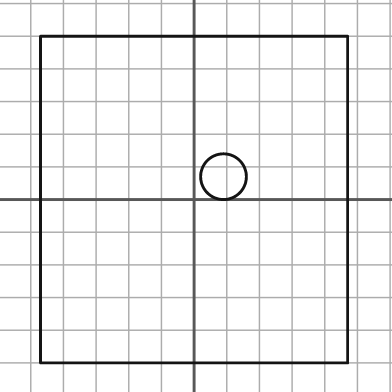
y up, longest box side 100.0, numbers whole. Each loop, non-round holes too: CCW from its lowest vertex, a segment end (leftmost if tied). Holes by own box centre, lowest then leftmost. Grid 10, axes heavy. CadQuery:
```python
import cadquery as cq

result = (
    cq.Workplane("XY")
    .moveTo(-47.0, -50.0)
    .lineTo(47.0, -50.0)
    .lineTo(47.0, 50.0)
    .lineTo(-47.0, 50.0)
    .close()
    .moveTo(9.0, 7.0)
    .circle(7.0)
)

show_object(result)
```